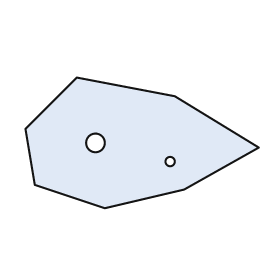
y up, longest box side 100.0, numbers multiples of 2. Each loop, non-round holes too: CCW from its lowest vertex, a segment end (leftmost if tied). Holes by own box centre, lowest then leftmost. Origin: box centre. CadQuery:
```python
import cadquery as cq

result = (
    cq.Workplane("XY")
    .moveTo(-16.0, -28.0)
    .lineTo(18.0, -20.0)
    .lineTo(50.0, -2.0)
    .lineTo(14.0, 20.0)
    .lineTo(-28.0, 28.0)
    .lineTo(-50.0, 6.0)
    .lineTo(-46.0, -18.0)
    .close()
    .moveTo(12.0, -8.0)
    .circle(2.0)
    .moveTo(-20.0, 0.0)
    .circle(4.0)
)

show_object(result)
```